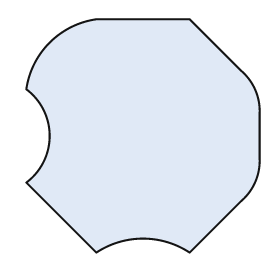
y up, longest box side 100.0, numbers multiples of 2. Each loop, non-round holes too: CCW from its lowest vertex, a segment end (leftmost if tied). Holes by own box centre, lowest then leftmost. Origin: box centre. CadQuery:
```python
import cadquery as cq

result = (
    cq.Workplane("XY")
    .moveTo(-20.0, -50.0)
    .threePointArc((0.0, -44.0), (20.0, -50.0))
    .lineTo(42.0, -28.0)
    .threePointArc((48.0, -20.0), (50.0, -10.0))
    .lineTo(50.0, 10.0)
    .threePointArc((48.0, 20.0), (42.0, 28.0))
    .lineTo(20.0, 50.0)
    .lineTo(-20.0, 50.0)
    .threePointArc((-40.0, 40.0), (-50.0, 20.0))
    .threePointArc((-40.0, 0.0), (-50.0, -20.0))
    .close()
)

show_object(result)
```